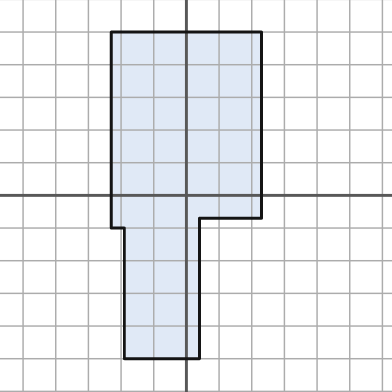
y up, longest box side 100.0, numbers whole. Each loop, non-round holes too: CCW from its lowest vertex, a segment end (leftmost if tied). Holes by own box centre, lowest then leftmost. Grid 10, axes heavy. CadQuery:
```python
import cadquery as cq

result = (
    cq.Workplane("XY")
    .moveTo(-19.0, -50.0)
    .lineTo(4.0, -50.0)
    .lineTo(4.0, -7.0)
    .lineTo(23.0, -7.0)
    .lineTo(23.0, 50.0)
    .lineTo(-23.0, 50.0)
    .lineTo(-23.0, -10.0)
    .lineTo(-19.0, -10.0)
    .close()
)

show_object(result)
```